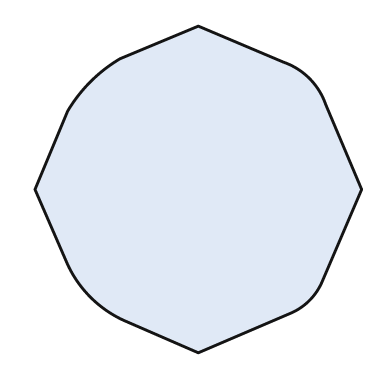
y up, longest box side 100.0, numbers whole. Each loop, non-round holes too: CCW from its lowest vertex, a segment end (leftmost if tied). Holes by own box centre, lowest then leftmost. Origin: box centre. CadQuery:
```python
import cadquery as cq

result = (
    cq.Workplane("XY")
    .moveTo(0.0, -50.0)
    .lineTo(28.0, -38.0)
    .threePointArc((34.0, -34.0), (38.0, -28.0))
    .lineTo(50.0, 0.0)
    .lineTo(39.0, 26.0)
    .threePointArc((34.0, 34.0), (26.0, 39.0))
    .lineTo(0.0, 50.0)
    .lineTo(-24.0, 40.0)
    .threePointArc((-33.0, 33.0), (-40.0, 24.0))
    .lineTo(-50.0, 0.0)
    .lineTo(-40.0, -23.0)
    .threePointArc((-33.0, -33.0), (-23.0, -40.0))
    .close()
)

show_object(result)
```